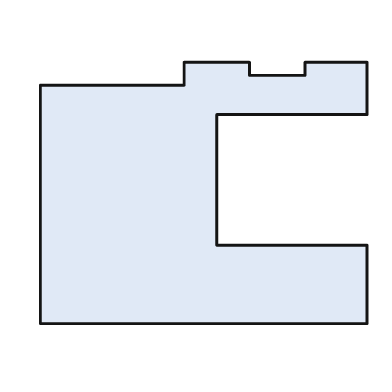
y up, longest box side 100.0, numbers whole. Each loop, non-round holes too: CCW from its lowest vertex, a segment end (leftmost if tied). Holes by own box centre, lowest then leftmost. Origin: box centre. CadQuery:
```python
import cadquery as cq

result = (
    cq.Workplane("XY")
    .moveTo(-50.0, -40.0)
    .lineTo(50.0, -40.0)
    .lineTo(50.0, -16.0)
    .lineTo(4.0, -16.0)
    .lineTo(4.0, 24.0)
    .lineTo(50.0, 24.0)
    .lineTo(50.0, 40.0)
    .lineTo(31.0, 40.0)
    .lineTo(31.0, 36.0)
    .lineTo(14.0, 36.0)
    .lineTo(14.0, 40.0)
    .lineTo(-6.0, 40.0)
    .lineTo(-6.0, 33.0)
    .lineTo(-50.0, 33.0)
    .close()
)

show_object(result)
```